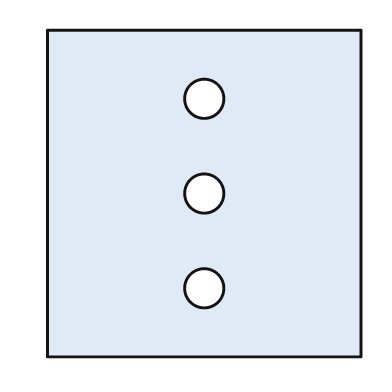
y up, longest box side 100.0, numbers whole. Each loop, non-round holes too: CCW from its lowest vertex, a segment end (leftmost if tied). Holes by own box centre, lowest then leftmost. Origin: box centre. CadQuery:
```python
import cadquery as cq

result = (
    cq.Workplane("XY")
    .moveTo(-48.0, -50.0)
    .lineTo(48.0, -50.0)
    .lineTo(48.0, 50.0)
    .lineTo(-48.0, 50.0)
    .close()
    .moveTo(0.0, -29.0)
    .circle(6.0)
    .moveTo(0.0, 0.0)
    .circle(6.0)
    .moveTo(0.0, 29.0)
    .circle(6.0)
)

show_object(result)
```